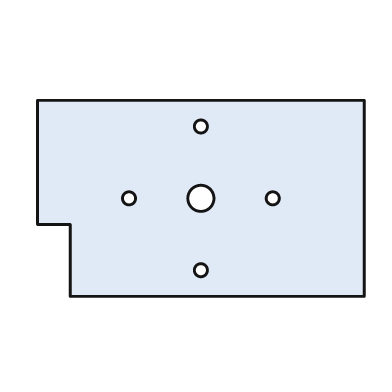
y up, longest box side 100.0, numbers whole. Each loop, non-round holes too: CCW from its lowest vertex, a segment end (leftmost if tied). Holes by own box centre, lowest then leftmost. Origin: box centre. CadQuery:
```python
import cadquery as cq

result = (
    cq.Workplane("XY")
    .moveTo(-40.0, -30.0)
    .lineTo(50.0, -30.0)
    .lineTo(50.0, 30.0)
    .lineTo(-50.0, 30.0)
    .lineTo(-50.0, -8.0)
    .lineTo(-40.0, -8.0)
    .close()
    .moveTo(0.0, -22.0)
    .circle(2.0)
    .moveTo(-22.0, 0.0)
    .circle(2.0)
    .moveTo(0.0, 0.0)
    .circle(4.0)
    .moveTo(22.0, 0.0)
    .circle(2.0)
    .moveTo(0.0, 22.0)
    .circle(2.0)
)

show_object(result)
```